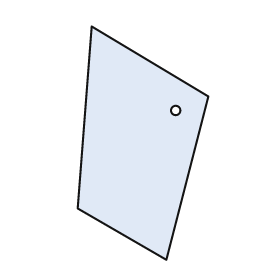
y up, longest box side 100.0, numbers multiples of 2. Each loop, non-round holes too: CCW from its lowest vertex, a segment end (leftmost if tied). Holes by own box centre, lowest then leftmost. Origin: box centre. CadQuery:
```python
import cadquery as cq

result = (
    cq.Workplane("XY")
    .moveTo(10.0, -50.0)
    .lineTo(28.0, 20.0)
    .lineTo(-22.0, 50.0)
    .lineTo(-28.0, -28.0)
    .close()
    .moveTo(14.0, 14.0)
    .circle(2.0)
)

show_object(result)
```